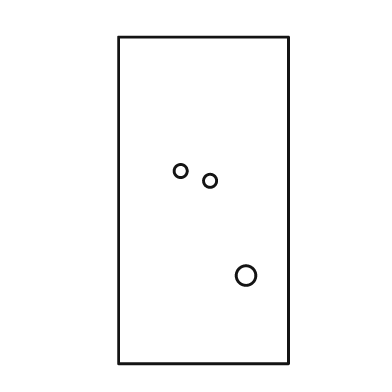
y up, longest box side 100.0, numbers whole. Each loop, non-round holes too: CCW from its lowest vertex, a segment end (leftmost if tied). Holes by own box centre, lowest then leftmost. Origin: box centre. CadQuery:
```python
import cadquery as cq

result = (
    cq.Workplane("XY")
    .moveTo(-26.0, -50.0)
    .lineTo(26.0, -50.0)
    .lineTo(26.0, 50.0)
    .lineTo(-26.0, 50.0)
    .close()
    .moveTo(13.0, -23.0)
    .circle(3.0)
    .moveTo(2.0, 6.0)
    .circle(2.0)
    .moveTo(-7.0, 9.0)
    .circle(2.0)
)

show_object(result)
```